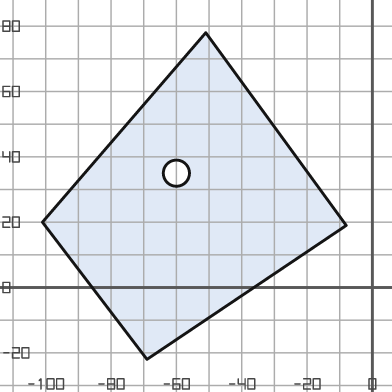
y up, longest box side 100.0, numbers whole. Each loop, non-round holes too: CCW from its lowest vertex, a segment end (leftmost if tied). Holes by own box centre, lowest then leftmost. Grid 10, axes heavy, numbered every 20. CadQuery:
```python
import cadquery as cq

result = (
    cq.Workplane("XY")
    .moveTo(-69.0, -22.0)
    .lineTo(-8.0, 19.0)
    .lineTo(-51.0, 78.0)
    .lineTo(-101.0, 20.0)
    .close()
    .moveTo(-60.0, 35.0)
    .circle(4.0)
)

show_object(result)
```